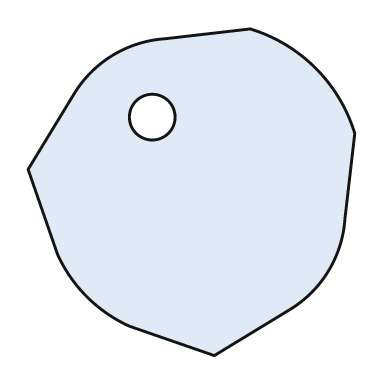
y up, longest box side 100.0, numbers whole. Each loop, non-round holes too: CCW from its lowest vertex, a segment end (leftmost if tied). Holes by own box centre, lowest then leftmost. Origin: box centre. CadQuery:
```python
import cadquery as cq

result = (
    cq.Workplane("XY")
    .moveTo(7.0, -50.0)
    .lineTo(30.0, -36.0)
    .threePointArc((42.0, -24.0), (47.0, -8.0))
    .lineTo(50.0, 18.0)
    .threePointArc((38.0, 38.0), (18.0, 50.0))
    .lineTo(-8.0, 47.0)
    .threePointArc((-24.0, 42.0), (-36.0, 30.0))
    .lineTo(-50.0, 7.0)
    .lineTo(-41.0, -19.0)
    .threePointArc((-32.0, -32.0), (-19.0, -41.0))
    .close()
    .moveTo(-12.0, 23.0)
    .circle(7.0)
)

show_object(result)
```